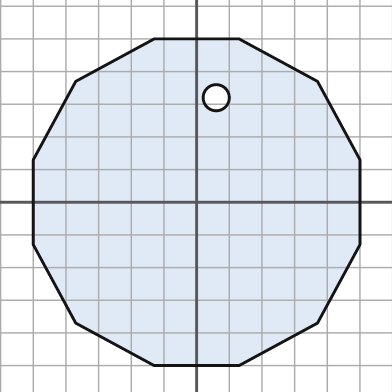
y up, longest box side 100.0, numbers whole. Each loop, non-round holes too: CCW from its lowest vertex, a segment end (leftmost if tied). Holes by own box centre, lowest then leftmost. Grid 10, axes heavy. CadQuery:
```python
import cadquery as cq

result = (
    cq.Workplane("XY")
    .moveTo(-13.0, -50.0)
    .lineTo(13.0, -50.0)
    .lineTo(37.0, -37.0)
    .lineTo(50.0, -13.0)
    .lineTo(50.0, 13.0)
    .lineTo(37.0, 37.0)
    .lineTo(13.0, 50.0)
    .lineTo(-13.0, 50.0)
    .lineTo(-37.0, 37.0)
    .lineTo(-50.0, 13.0)
    .lineTo(-50.0, -13.0)
    .lineTo(-37.0, -37.0)
    .close()
    .moveTo(6.0, 32.0)
    .circle(4.0)
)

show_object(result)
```